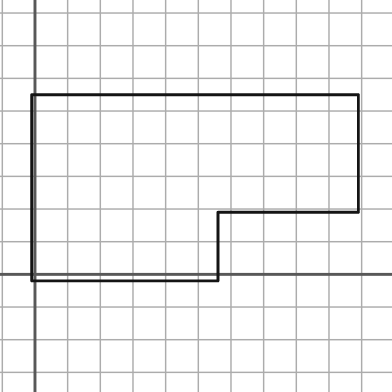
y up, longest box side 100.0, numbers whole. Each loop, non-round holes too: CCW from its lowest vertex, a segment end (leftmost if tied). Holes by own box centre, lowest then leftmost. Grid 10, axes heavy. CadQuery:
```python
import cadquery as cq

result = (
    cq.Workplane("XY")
    .moveTo(-1.0, -2.0)
    .lineTo(56.0, -2.0)
    .lineTo(56.0, 19.0)
    .lineTo(99.0, 19.0)
    .lineTo(99.0, 55.0)
    .lineTo(-1.0, 55.0)
    .close()
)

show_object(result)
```